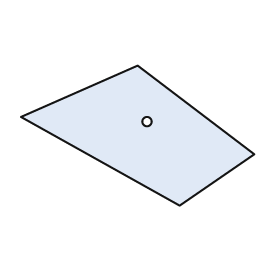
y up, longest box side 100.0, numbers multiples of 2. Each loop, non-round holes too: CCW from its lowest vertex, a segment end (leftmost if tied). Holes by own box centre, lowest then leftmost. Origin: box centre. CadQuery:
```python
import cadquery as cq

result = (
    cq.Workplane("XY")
    .moveTo(18.0, -30.0)
    .lineTo(50.0, -8.0)
    .lineTo(0.0, 30.0)
    .lineTo(-50.0, 8.0)
    .close()
    .moveTo(4.0, 6.0)
    .circle(2.0)
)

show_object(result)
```